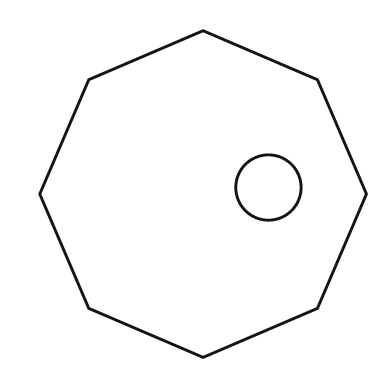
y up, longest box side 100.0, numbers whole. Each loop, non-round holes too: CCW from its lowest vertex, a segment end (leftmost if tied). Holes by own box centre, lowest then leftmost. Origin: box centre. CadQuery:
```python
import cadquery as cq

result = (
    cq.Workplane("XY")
    .moveTo(0.0, -50.0)
    .lineTo(35.0, -35.0)
    .lineTo(50.0, 0.0)
    .lineTo(35.0, 35.0)
    .lineTo(0.0, 50.0)
    .lineTo(-35.0, 35.0)
    .lineTo(-50.0, 0.0)
    .lineTo(-35.0, -35.0)
    .close()
    .moveTo(20.0, 2.0)
    .circle(10.0)
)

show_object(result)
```